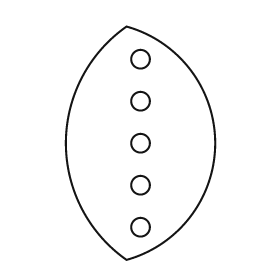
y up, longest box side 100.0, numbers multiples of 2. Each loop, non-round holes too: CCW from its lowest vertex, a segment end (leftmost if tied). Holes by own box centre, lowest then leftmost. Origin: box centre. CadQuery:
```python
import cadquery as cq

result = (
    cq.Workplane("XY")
    .moveTo(-6.0, -50.0)
    .threePointArc((32.0, 0.0), (-6.0, 50.0))
    .threePointArc((-32.0, 0.0), (-6.0, -50.0))
    .close()
    .moveTo(0.0, -36.0)
    .circle(4.0)
    .moveTo(0.0, -18.0)
    .circle(4.0)
    .moveTo(0.0, 0.0)
    .circle(4.0)
    .moveTo(0.0, 18.0)
    .circle(4.0)
    .moveTo(0.0, 36.0)
    .circle(4.0)
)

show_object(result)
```